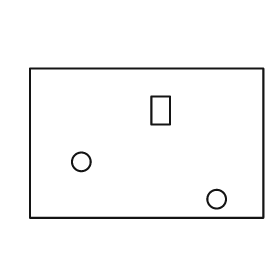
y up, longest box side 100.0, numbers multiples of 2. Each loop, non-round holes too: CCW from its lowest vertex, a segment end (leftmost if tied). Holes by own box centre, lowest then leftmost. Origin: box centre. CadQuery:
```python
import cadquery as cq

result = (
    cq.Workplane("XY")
    .moveTo(-50.0, -32.0)
    .lineTo(50.0, -32.0)
    .lineTo(50.0, 32.0)
    .lineTo(-50.0, 32.0)
    .close()
    .moveTo(30.0, -24.0)
    .circle(4.0)
    .moveTo(-28.0, -8.0)
    .circle(4.0)
    .moveTo(2.0, 8.0)
    .lineTo(10.0, 8.0)
    .lineTo(10.0, 20.0)
    .lineTo(2.0, 20.0)
    .close()
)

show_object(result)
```